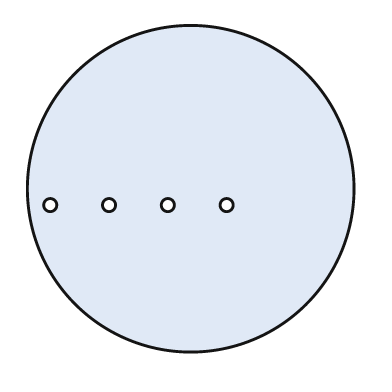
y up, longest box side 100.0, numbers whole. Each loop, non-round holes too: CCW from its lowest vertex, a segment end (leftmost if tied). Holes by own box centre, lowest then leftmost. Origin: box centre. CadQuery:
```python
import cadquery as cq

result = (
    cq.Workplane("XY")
    .moveTo(0.0, 0.0)
    .circle(50.0)
    .moveTo(-43.0, -5.0)
    .circle(2.0)
    .moveTo(-25.0, -5.0)
    .circle(2.0)
    .moveTo(-7.0, -5.0)
    .circle(2.0)
    .moveTo(11.0, -5.0)
    .circle(2.0)
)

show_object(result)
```